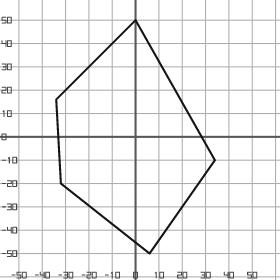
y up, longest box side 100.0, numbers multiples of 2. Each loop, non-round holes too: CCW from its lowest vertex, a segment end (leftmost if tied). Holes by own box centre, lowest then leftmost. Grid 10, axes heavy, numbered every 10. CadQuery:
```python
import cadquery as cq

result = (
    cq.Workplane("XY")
    .moveTo(6.0, -50.0)
    .lineTo(34.0, -10.0)
    .lineTo(0.0, 50.0)
    .lineTo(-34.0, 16.0)
    .lineTo(-32.0, -20.0)
    .close()
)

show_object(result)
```